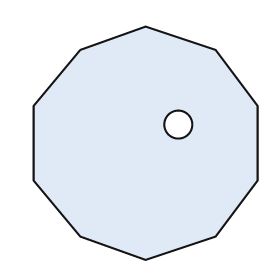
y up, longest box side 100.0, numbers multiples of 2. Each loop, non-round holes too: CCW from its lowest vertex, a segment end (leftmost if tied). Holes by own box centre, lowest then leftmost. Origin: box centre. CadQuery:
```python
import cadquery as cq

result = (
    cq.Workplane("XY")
    .moveTo(0.0, -50.0)
    .lineTo(30.0, -40.0)
    .lineTo(48.0, -16.0)
    .lineTo(48.0, 16.0)
    .lineTo(30.0, 40.0)
    .lineTo(0.0, 50.0)
    .lineTo(-28.0, 40.0)
    .lineTo(-48.0, 16.0)
    .lineTo(-48.0, -16.0)
    .lineTo(-28.0, -40.0)
    .close()
    .moveTo(14.0, 8.0)
    .circle(6.0)
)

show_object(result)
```